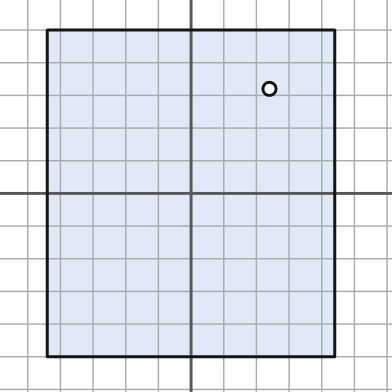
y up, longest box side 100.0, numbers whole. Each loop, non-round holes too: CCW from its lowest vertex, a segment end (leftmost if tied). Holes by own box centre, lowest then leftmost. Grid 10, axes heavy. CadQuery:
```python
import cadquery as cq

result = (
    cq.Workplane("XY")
    .moveTo(-44.0, -50.0)
    .lineTo(44.0, -50.0)
    .lineTo(44.0, 50.0)
    .lineTo(-44.0, 50.0)
    .close()
    .moveTo(24.0, 32.0)
    .circle(2.0)
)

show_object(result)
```